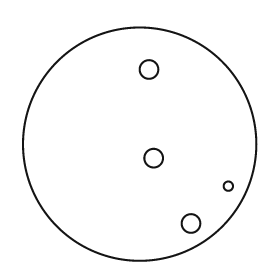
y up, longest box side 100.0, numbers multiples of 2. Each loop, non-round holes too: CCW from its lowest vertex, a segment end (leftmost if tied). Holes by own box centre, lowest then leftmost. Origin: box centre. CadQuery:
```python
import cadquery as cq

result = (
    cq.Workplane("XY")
    .moveTo(0.0, 0.0)
    .circle(50.0)
    .moveTo(22.0, -34.0)
    .circle(4.0)
    .moveTo(38.0, -18.0)
    .circle(2.0)
    .moveTo(6.0, -6.0)
    .circle(4.0)
    .moveTo(4.0, 32.0)
    .circle(4.0)
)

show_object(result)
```